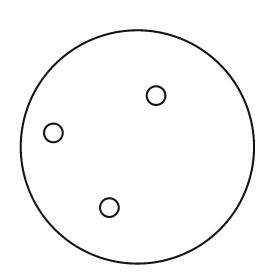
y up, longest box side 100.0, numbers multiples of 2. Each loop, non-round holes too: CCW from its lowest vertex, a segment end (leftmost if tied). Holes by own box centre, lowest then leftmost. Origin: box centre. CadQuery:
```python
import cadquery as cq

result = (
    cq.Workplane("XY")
    .moveTo(0.0, 0.0)
    .circle(50.0)
    .moveTo(-12.0, -26.0)
    .circle(4.0)
    .moveTo(-36.0, 6.0)
    .circle(4.0)
    .moveTo(8.0, 22.0)
    .circle(4.0)
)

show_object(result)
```